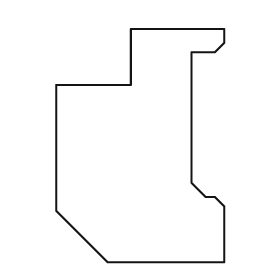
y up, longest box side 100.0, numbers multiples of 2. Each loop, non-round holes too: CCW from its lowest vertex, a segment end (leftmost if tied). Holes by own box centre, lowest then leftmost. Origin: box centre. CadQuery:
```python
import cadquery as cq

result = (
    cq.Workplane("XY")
    .moveTo(-14.0, -50.0)
    .lineTo(36.0, -50.0)
    .lineTo(36.0, -26.0)
    .lineTo(32.0, -22.0)
    .lineTo(28.0, -22.0)
    .lineTo(22.0, -16.0)
    .lineTo(22.0, 40.0)
    .lineTo(32.0, 40.0)
    .lineTo(36.0, 44.0)
    .lineTo(36.0, 50.0)
    .lineTo(-4.0, 50.0)
    .lineTo(-4.0, 26.0)
    .lineTo(-36.0, 26.0)
    .lineTo(-36.0, -28.0)
    .close()
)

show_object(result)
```